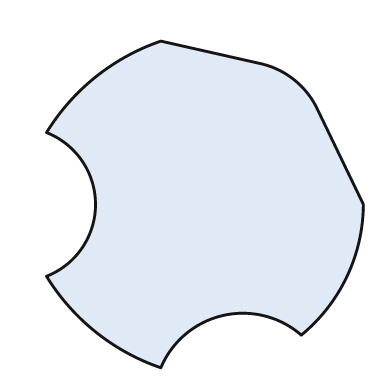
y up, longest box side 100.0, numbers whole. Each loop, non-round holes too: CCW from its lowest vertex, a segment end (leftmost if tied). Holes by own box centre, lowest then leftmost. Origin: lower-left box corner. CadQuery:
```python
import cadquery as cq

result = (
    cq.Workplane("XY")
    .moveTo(35.0, 0.0)
    .threePointArc((54.0, 16.0), (78.0, 10.0))
    .threePointArc((92.0, 28.0), (97.0, 50.0))
    .lineTo(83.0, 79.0)
    .threePointArc((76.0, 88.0), (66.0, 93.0))
    .lineTo(35.0, 100.0)
    .threePointArc((15.0, 89.0), (0.0, 72.0))
    .threePointArc((15.0, 50.0), (0.0, 28.0))
    .threePointArc((15.0, 11.0), (35.0, 0.0))
    .close()
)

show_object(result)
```